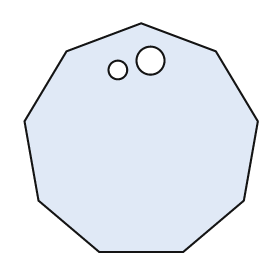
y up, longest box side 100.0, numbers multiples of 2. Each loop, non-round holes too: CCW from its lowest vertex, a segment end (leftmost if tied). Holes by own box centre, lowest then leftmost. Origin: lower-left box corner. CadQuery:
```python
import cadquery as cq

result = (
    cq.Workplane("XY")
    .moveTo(32.0, 0.0)
    .lineTo(68.0, 0.0)
    .lineTo(94.0, 22.0)
    .lineTo(100.0, 56.0)
    .lineTo(82.0, 86.0)
    .lineTo(50.0, 98.0)
    .lineTo(18.0, 86.0)
    .lineTo(0.0, 56.0)
    .lineTo(6.0, 22.0)
    .close()
    .moveTo(40.0, 78.0)
    .circle(4.0)
    .moveTo(54.0, 82.0)
    .circle(6.0)
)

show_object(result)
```